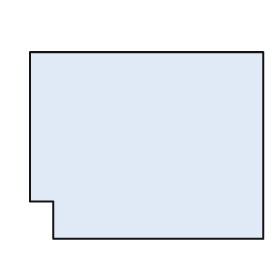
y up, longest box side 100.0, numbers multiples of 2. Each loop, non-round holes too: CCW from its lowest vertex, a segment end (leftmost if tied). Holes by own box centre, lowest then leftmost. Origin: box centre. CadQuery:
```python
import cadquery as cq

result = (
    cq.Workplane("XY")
    .moveTo(-40.0, -40.0)
    .lineTo(50.0, -40.0)
    .lineTo(50.0, 40.0)
    .lineTo(-50.0, 40.0)
    .lineTo(-50.0, -24.0)
    .lineTo(-40.0, -24.0)
    .close()
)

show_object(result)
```